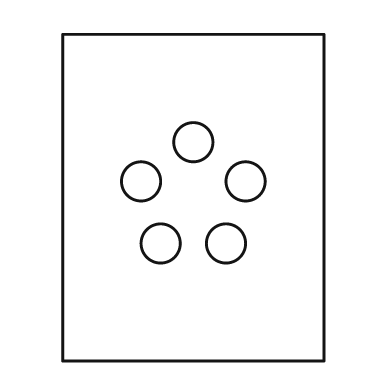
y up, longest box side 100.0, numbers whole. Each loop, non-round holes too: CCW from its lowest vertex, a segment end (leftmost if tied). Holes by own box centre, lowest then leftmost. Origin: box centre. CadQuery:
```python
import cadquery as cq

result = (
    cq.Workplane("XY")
    .moveTo(-40.0, -50.0)
    .lineTo(40.0, -50.0)
    .lineTo(40.0, 50.0)
    .lineTo(-40.0, 50.0)
    .close()
    .moveTo(-10.0, -14.0)
    .circle(6.0)
    .moveTo(10.0, -14.0)
    .circle(6.0)
    .moveTo(-16.0, 5.0)
    .circle(6.0)
    .moveTo(16.0, 5.0)
    .circle(6.0)
    .moveTo(0.0, 17.0)
    .circle(6.0)
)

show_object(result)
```